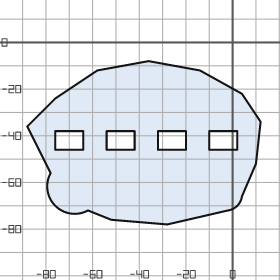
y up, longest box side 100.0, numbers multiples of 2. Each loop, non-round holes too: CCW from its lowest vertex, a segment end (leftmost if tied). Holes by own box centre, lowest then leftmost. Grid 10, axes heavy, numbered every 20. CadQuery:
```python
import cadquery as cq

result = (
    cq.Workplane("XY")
    .moveTo(-28.0, -78.0)
    .lineTo(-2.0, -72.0)
    .threePointArc((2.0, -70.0), (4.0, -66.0))
    .lineTo(10.0, -52.0)
    .lineTo(12.0, -34.0)
    .lineTo(4.0, -22.0)
    .lineTo(-14.0, -12.0)
    .lineTo(-36.0, -8.0)
    .lineTo(-58.0, -12.0)
    .lineTo(-76.0, -24.0)
    .lineTo(-88.0, -36.0)
    .lineTo(-78.0, -56.0)
    .threePointArc((-76.0, -70.0), (-62.0, -72.0))
    .lineTo(-52.0, -76.0)
    .close()
    .moveTo(-76.0, -46.0)
    .lineTo(-64.0, -46.0)
    .lineTo(-64.0, -38.0)
    .lineTo(-76.0, -38.0)
    .close()
    .moveTo(-54.0, -46.0)
    .lineTo(-42.0, -46.0)
    .lineTo(-42.0, -38.0)
    .lineTo(-54.0, -38.0)
    .close()
    .moveTo(-32.0, -46.0)
    .lineTo(-20.0, -46.0)
    .lineTo(-20.0, -38.0)
    .lineTo(-32.0, -38.0)
    .close()
    .moveTo(-10.0, -46.0)
    .lineTo(2.0, -46.0)
    .lineTo(2.0, -38.0)
    .lineTo(-10.0, -38.0)
    .close()
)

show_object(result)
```